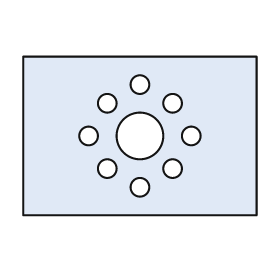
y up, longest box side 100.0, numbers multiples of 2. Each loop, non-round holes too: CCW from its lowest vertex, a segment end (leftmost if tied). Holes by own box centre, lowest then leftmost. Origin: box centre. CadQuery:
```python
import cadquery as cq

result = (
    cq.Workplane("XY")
    .moveTo(-50.0, -34.0)
    .lineTo(50.0, -34.0)
    .lineTo(50.0, 34.0)
    .lineTo(-50.0, 34.0)
    .close()
    .moveTo(0.0, -22.0)
    .circle(4.0)
    .moveTo(-14.0, -14.0)
    .circle(4.0)
    .moveTo(14.0, -14.0)
    .circle(4.0)
    .moveTo(-22.0, 0.0)
    .circle(4.0)
    .moveTo(0.0, 0.0)
    .circle(10.0)
    .moveTo(22.0, 0.0)
    .circle(4.0)
    .moveTo(-14.0, 14.0)
    .circle(4.0)
    .moveTo(14.0, 14.0)
    .circle(4.0)
    .moveTo(0.0, 22.0)
    .circle(4.0)
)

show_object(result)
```